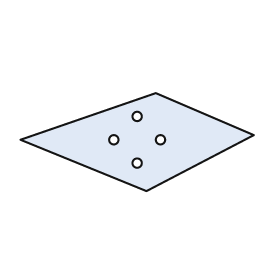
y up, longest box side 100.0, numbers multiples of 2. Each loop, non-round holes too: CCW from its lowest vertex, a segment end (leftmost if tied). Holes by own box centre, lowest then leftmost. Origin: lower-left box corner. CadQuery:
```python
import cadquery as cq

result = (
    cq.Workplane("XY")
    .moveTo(54.0, 0.0)
    .lineTo(100.0, 24.0)
    .lineTo(58.0, 42.0)
    .lineTo(0.0, 22.0)
    .close()
    .moveTo(50.0, 12.0)
    .circle(2.0)
    .moveTo(40.0, 22.0)
    .circle(2.0)
    .moveTo(60.0, 22.0)
    .circle(2.0)
    .moveTo(50.0, 32.0)
    .circle(2.0)
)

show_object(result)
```